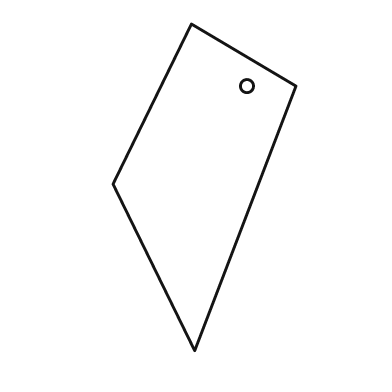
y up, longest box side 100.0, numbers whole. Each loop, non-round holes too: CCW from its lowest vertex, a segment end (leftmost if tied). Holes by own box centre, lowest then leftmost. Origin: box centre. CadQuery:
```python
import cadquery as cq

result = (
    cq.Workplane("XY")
    .moveTo(-3.0, -50.0)
    .lineTo(28.0, 31.0)
    .lineTo(-4.0, 50.0)
    .lineTo(-28.0, 1.0)
    .close()
    .moveTo(13.0, 31.0)
    .circle(2.0)
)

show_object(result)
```